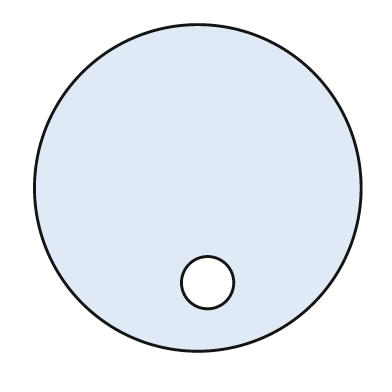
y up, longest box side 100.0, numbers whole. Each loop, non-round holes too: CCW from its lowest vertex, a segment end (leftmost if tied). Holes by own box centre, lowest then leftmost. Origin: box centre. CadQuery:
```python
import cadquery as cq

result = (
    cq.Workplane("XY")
    .moveTo(0.0, 0.0)
    .circle(50.0)
    .moveTo(3.0, -29.0)
    .circle(8.0)
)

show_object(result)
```